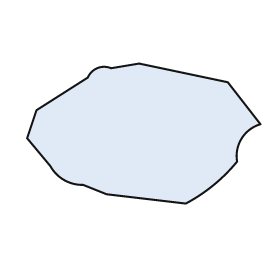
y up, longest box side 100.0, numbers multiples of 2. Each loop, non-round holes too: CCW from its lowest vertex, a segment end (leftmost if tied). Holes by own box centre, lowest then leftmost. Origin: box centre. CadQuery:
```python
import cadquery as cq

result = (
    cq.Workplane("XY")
    .moveTo(18.0, -30.0)
    .threePointArc((30.0, -22.0), (40.0, -12.0))
    .threePointArc((42.0, -2.0), (50.0, 4.0))
    .lineTo(36.0, 22.0)
    .lineTo(-2.0, 30.0)
    .lineTo(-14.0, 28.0)
    .threePointArc((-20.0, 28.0), (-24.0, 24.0))
    .lineTo(-46.0, 10.0)
    .lineTo(-50.0, -2.0)
    .lineTo(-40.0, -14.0)
    .threePointArc((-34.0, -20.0), (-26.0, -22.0))
    .lineTo(-16.0, -26.0)
    .close()
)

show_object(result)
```